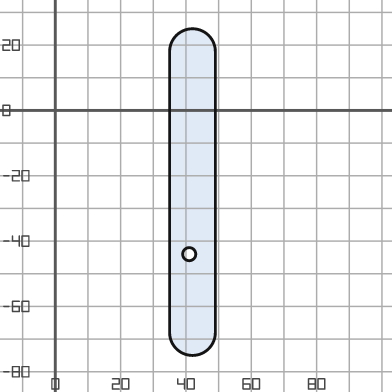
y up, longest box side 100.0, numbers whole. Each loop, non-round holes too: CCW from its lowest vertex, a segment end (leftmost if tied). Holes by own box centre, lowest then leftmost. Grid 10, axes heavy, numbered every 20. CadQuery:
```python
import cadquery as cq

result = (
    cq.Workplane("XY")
    .moveTo(35.0, -68.0)
    .threePointArc((42.0, -75.0), (49.0, -68.0))
    .lineTo(49.0, 18.0)
    .threePointArc((42.0, 25.0), (35.0, 18.0))
    .close()
    .moveTo(41.0, -44.0)
    .circle(2.0)
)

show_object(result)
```